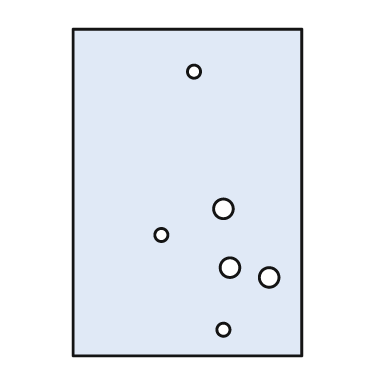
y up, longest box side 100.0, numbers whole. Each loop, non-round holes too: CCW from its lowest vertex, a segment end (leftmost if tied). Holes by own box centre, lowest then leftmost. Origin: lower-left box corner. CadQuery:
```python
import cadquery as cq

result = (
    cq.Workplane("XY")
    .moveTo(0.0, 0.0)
    .lineTo(70.0, 0.0)
    .lineTo(70.0, 100.0)
    .lineTo(0.0, 100.0)
    .close()
    .moveTo(46.0, 8.0)
    .circle(2.0)
    .moveTo(60.0, 24.0)
    .circle(3.0)
    .moveTo(48.0, 27.0)
    .circle(3.0)
    .moveTo(27.0, 37.0)
    .circle(2.0)
    .moveTo(46.0, 45.0)
    .circle(3.0)
    .moveTo(37.0, 87.0)
    .circle(2.0)
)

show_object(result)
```